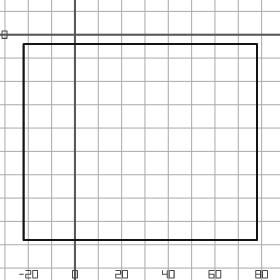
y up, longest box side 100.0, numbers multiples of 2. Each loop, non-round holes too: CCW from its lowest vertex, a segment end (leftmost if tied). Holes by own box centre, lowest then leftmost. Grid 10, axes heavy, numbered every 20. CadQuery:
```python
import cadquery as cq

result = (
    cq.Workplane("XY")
    .moveTo(-22.0, -88.0)
    .lineTo(78.0, -88.0)
    .lineTo(78.0, -4.0)
    .lineTo(-22.0, -4.0)
    .close()
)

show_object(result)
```